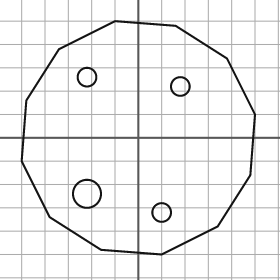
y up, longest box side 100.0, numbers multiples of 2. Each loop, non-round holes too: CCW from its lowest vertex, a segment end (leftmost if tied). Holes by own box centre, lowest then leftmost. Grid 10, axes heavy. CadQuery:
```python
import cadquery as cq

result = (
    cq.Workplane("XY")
    .moveTo(10.0, -50.0)
    .lineTo(34.0, -38.0)
    .lineTo(48.0, -16.0)
    .lineTo(50.0, 10.0)
    .lineTo(38.0, 34.0)
    .lineTo(16.0, 48.0)
    .lineTo(-10.0, 50.0)
    .lineTo(-34.0, 38.0)
    .lineTo(-48.0, 16.0)
    .lineTo(-50.0, -10.0)
    .lineTo(-38.0, -34.0)
    .lineTo(-16.0, -48.0)
    .close()
    .moveTo(10.0, -32.0)
    .circle(4.0)
    .moveTo(-22.0, -24.0)
    .circle(6.0)
    .moveTo(18.0, 22.0)
    .circle(4.0)
    .moveTo(-22.0, 26.0)
    .circle(4.0)
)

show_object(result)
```